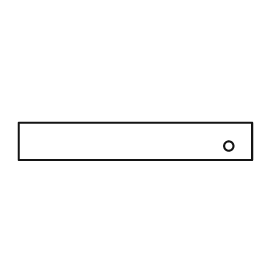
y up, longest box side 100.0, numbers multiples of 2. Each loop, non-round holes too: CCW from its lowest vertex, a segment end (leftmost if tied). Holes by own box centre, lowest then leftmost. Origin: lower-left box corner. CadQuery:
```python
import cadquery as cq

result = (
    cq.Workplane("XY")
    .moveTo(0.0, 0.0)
    .lineTo(100.0, 0.0)
    .lineTo(100.0, 16.0)
    .lineTo(0.0, 16.0)
    .close()
    .moveTo(90.0, 6.0)
    .circle(2.0)
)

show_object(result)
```